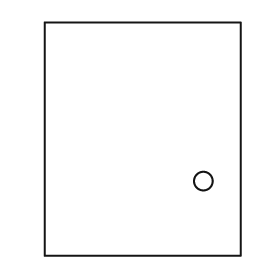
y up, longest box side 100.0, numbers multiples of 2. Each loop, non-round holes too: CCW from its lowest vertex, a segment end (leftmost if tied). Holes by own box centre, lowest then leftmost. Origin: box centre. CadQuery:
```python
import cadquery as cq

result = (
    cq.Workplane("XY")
    .moveTo(-42.0, -50.0)
    .lineTo(42.0, -50.0)
    .lineTo(42.0, 50.0)
    .lineTo(-42.0, 50.0)
    .close()
    .moveTo(26.0, -18.0)
    .circle(4.0)
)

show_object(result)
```